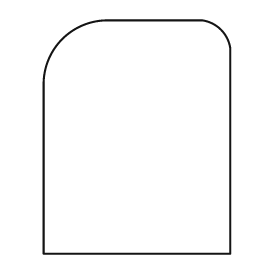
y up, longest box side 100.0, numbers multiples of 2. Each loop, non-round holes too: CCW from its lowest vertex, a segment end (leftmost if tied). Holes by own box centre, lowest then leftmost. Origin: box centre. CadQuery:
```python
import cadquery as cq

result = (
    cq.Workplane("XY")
    .moveTo(-40.0, -50.0)
    .lineTo(40.0, -50.0)
    .lineTo(40.0, 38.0)
    .threePointArc((36.0, 46.0), (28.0, 50.0))
    .lineTo(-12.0, 50.0)
    .threePointArc((-32.0, 42.0), (-40.0, 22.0))
    .close()
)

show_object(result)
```